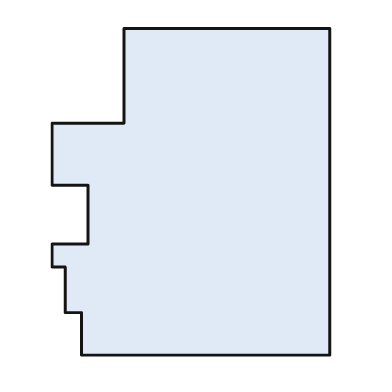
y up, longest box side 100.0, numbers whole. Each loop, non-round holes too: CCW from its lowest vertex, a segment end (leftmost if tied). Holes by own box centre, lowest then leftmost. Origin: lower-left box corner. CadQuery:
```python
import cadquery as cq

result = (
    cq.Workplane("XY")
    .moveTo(9.0, 0.0)
    .lineTo(85.0, 0.0)
    .lineTo(85.0, 100.0)
    .lineTo(22.0, 100.0)
    .lineTo(22.0, 71.0)
    .lineTo(0.0, 71.0)
    .lineTo(0.0, 52.0)
    .lineTo(11.0, 52.0)
    .lineTo(11.0, 34.0)
    .lineTo(0.0, 34.0)
    .lineTo(0.0, 27.0)
    .lineTo(4.0, 27.0)
    .lineTo(4.0, 13.0)
    .lineTo(9.0, 13.0)
    .close()
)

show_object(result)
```